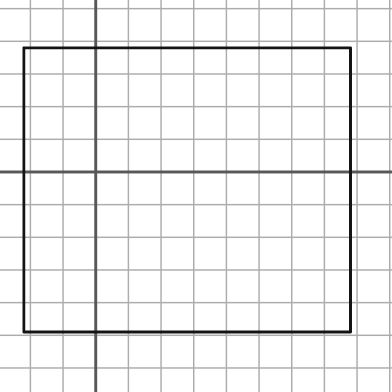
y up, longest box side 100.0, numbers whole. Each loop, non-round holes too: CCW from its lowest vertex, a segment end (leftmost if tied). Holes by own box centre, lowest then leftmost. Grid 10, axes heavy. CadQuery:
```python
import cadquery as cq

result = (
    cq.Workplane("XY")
    .moveTo(-22.0, -49.0)
    .lineTo(78.0, -49.0)
    .lineTo(78.0, 38.0)
    .lineTo(-22.0, 38.0)
    .close()
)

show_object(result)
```